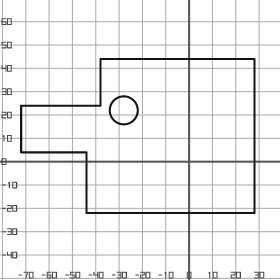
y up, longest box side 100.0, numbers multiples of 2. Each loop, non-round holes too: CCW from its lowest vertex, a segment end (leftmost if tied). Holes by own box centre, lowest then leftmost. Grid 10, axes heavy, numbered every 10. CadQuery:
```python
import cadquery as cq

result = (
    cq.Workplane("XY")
    .moveTo(-44.0, -22.0)
    .lineTo(28.0, -22.0)
    .lineTo(28.0, 44.0)
    .lineTo(-38.0, 44.0)
    .lineTo(-38.0, 24.0)
    .lineTo(-72.0, 24.0)
    .lineTo(-72.0, 4.0)
    .lineTo(-44.0, 4.0)
    .close()
    .moveTo(-28.0, 22.0)
    .circle(6.0)
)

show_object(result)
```